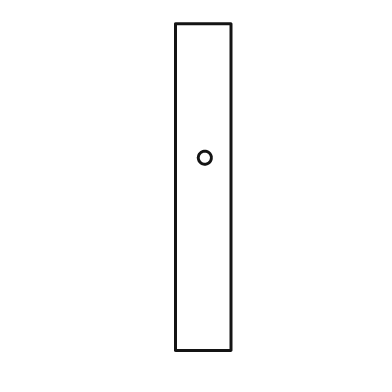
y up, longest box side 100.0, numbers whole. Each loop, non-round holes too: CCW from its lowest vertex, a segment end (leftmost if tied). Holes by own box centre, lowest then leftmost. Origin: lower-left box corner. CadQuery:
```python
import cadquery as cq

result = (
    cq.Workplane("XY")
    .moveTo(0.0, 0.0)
    .lineTo(17.0, 0.0)
    .lineTo(17.0, 100.0)
    .lineTo(0.0, 100.0)
    .close()
    .moveTo(9.0, 59.0)
    .circle(2.0)
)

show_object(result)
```